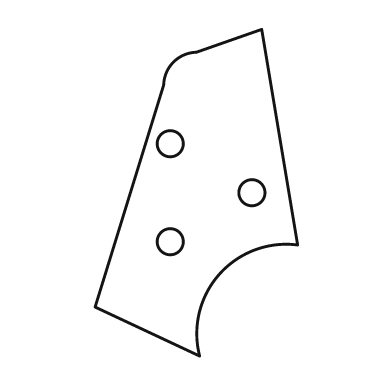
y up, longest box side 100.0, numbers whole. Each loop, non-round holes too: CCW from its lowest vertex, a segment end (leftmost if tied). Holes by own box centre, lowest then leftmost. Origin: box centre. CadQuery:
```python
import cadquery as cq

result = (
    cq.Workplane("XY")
    .moveTo(1.0, -50.0)
    .threePointArc((7.0, -25.0), (31.0, -16.0))
    .lineTo(20.0, 50.0)
    .lineTo(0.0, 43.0)
    .threePointArc((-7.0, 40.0), (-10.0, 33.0))
    .lineTo(-31.0, -35.0)
    .close()
    .moveTo(-8.0, -15.0)
    .circle(4.0)
    .moveTo(17.0, 0.0)
    .circle(4.0)
    .moveTo(-8.0, 15.0)
    .circle(4.0)
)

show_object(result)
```